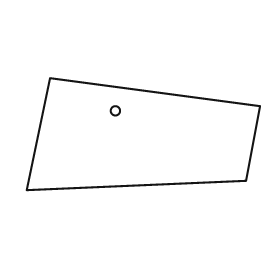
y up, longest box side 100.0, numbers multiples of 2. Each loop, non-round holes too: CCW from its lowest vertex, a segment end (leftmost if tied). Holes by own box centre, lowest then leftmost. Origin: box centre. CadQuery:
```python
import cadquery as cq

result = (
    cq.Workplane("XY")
    .moveTo(-50.0, -24.0)
    .lineTo(44.0, -20.0)
    .lineTo(50.0, 12.0)
    .lineTo(-40.0, 24.0)
    .close()
    .moveTo(-12.0, 10.0)
    .circle(2.0)
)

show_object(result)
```